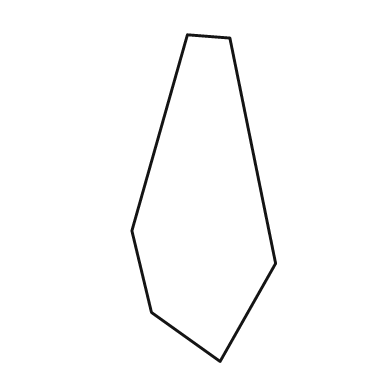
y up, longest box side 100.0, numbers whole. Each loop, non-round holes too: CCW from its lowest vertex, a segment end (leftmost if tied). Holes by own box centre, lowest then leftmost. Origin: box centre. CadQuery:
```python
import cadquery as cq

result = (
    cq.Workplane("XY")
    .moveTo(5.0, -50.0)
    .lineTo(22.0, -20.0)
    .lineTo(8.0, 49.0)
    .lineTo(-5.0, 50.0)
    .lineTo(-22.0, -10.0)
    .lineTo(-16.0, -35.0)
    .close()
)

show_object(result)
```